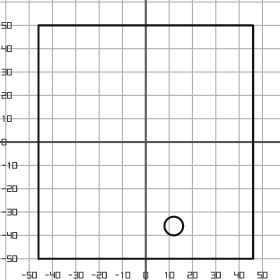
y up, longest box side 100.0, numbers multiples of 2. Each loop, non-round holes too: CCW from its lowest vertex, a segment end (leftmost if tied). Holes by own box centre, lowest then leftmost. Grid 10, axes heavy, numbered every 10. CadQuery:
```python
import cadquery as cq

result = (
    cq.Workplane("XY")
    .moveTo(-46.0, -50.0)
    .lineTo(46.0, -50.0)
    .lineTo(46.0, 50.0)
    .lineTo(-46.0, 50.0)
    .close()
    .moveTo(12.0, -36.0)
    .circle(4.0)
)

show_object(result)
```